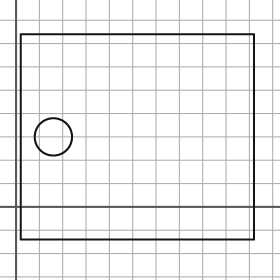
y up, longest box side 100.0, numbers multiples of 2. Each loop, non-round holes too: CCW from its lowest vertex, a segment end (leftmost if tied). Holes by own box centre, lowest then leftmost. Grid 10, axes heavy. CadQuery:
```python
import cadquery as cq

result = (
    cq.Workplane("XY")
    .moveTo(2.0, -14.0)
    .lineTo(102.0, -14.0)
    .lineTo(102.0, 74.0)
    .lineTo(2.0, 74.0)
    .close()
    .moveTo(16.0, 30.0)
    .circle(8.0)
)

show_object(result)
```